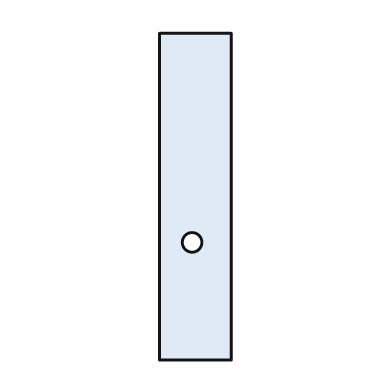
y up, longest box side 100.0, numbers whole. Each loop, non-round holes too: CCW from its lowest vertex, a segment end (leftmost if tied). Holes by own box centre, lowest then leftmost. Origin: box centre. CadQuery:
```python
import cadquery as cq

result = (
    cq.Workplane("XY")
    .moveTo(-11.0, -50.0)
    .lineTo(11.0, -50.0)
    .lineTo(11.0, 50.0)
    .lineTo(-11.0, 50.0)
    .close()
    .moveTo(-1.0, -14.0)
    .circle(3.0)
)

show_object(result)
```